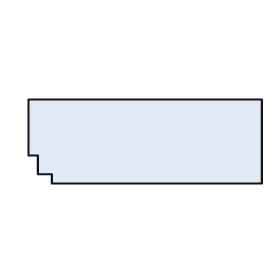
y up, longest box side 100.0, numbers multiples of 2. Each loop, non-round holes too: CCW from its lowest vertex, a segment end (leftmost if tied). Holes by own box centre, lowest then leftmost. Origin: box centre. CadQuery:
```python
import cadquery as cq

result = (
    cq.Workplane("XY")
    .moveTo(-40.0, -18.0)
    .lineTo(50.0, -18.0)
    .lineTo(50.0, 18.0)
    .lineTo(-50.0, 18.0)
    .lineTo(-50.0, -6.0)
    .lineTo(-46.0, -6.0)
    .lineTo(-46.0, -14.0)
    .lineTo(-40.0, -14.0)
    .close()
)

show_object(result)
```